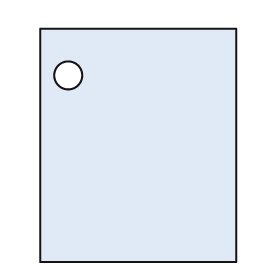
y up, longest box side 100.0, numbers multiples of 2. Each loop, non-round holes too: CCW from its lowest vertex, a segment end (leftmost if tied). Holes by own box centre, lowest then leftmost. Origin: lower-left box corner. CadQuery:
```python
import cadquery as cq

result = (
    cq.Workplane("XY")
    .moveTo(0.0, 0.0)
    .lineTo(84.0, 0.0)
    .lineTo(84.0, 100.0)
    .lineTo(0.0, 100.0)
    .close()
    .moveTo(12.0, 80.0)
    .circle(6.0)
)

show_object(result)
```